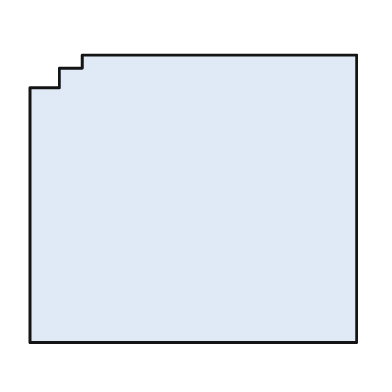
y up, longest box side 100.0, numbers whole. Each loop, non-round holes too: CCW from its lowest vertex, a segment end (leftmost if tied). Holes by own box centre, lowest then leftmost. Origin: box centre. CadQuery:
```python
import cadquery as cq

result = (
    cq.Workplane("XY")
    .moveTo(-50.0, -44.0)
    .lineTo(50.0, -44.0)
    .lineTo(50.0, 44.0)
    .lineTo(-34.0, 44.0)
    .lineTo(-34.0, 40.0)
    .lineTo(-41.0, 40.0)
    .lineTo(-41.0, 34.0)
    .lineTo(-50.0, 34.0)
    .close()
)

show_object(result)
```